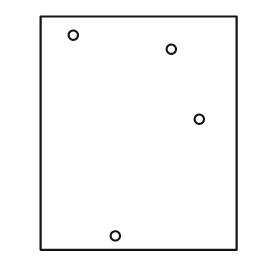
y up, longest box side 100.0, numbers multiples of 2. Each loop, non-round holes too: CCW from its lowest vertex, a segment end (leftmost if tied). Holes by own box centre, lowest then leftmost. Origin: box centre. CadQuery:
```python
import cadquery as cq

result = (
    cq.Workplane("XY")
    .moveTo(-42.0, -50.0)
    .lineTo(42.0, -50.0)
    .lineTo(42.0, 50.0)
    .lineTo(-42.0, 50.0)
    .close()
    .moveTo(-10.0, -44.0)
    .circle(2.0)
    .moveTo(26.0, 6.0)
    .circle(2.0)
    .moveTo(14.0, 36.0)
    .circle(2.0)
    .moveTo(-28.0, 42.0)
    .circle(2.0)
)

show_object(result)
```